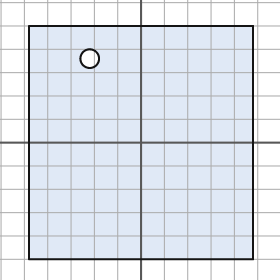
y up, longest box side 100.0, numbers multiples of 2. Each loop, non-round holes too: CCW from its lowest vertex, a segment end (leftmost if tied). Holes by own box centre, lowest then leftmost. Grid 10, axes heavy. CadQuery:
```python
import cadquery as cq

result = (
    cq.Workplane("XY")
    .moveTo(-48.0, -50.0)
    .lineTo(48.0, -50.0)
    .lineTo(48.0, 50.0)
    .lineTo(-48.0, 50.0)
    .close()
    .moveTo(-22.0, 36.0)
    .circle(4.0)
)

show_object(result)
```